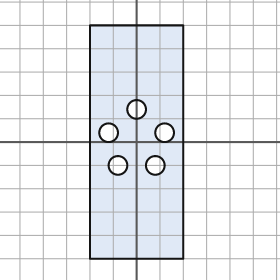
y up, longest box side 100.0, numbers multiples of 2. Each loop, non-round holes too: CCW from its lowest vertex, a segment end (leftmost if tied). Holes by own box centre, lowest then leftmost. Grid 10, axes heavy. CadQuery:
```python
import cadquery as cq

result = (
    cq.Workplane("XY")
    .moveTo(-20.0, -50.0)
    .lineTo(20.0, -50.0)
    .lineTo(20.0, 50.0)
    .lineTo(-20.0, 50.0)
    .close()
    .moveTo(-8.0, -10.0)
    .circle(4.0)
    .moveTo(8.0, -10.0)
    .circle(4.0)
    .moveTo(-12.0, 4.0)
    .circle(4.0)
    .moveTo(12.0, 4.0)
    .circle(4.0)
    .moveTo(0.0, 14.0)
    .circle(4.0)
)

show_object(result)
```